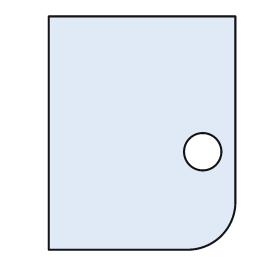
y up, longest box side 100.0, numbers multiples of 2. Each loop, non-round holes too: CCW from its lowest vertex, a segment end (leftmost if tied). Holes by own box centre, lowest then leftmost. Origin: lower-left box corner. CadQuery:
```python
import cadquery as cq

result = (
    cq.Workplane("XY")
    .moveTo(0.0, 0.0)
    .lineTo(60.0, 0.0)
    .threePointArc((74.0, 6.0), (80.0, 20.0))
    .lineTo(80.0, 100.0)
    .lineTo(0.0, 100.0)
    .close()
    .moveTo(66.0, 42.0)
    .circle(8.0)
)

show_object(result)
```